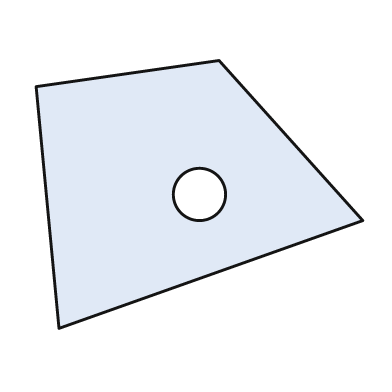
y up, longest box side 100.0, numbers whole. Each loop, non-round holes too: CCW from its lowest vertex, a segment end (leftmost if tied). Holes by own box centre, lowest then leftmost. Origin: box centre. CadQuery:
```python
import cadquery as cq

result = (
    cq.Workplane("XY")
    .moveTo(-43.0, -41.0)
    .lineTo(50.0, -8.0)
    .lineTo(6.0, 41.0)
    .lineTo(-50.0, 33.0)
    .close()
    .moveTo(0.0, 0.0)
    .circle(8.0)
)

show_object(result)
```